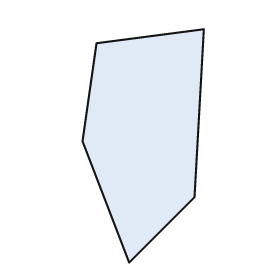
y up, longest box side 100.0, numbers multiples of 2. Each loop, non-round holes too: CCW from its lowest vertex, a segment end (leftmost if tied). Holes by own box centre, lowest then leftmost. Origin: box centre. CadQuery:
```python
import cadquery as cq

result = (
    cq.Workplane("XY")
    .moveTo(-6.0, -50.0)
    .lineTo(22.0, -22.0)
    .lineTo(26.0, 50.0)
    .lineTo(-20.0, 44.0)
    .lineTo(-26.0, 2.0)
    .close()
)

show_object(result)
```